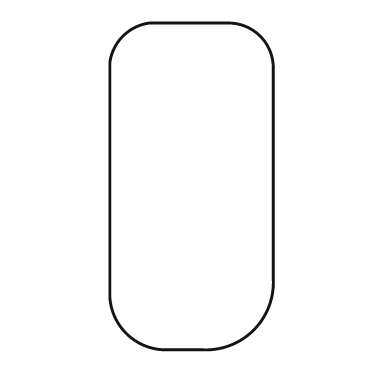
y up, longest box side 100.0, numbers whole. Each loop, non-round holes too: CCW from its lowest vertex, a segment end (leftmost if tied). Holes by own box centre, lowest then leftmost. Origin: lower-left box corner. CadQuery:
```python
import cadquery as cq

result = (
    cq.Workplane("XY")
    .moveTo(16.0, 0.0)
    .lineTo(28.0, 0.0)
    .threePointArc((44.0, 6.0), (50.0, 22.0))
    .lineTo(50.0, 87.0)
    .threePointArc((46.0, 96.0), (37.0, 100.0))
    .lineTo(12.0, 100.0)
    .threePointArc((4.0, 96.0), (0.0, 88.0))
    .lineTo(0.0, 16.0)
    .threePointArc((5.0, 5.0), (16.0, 0.0))
    .close()
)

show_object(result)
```